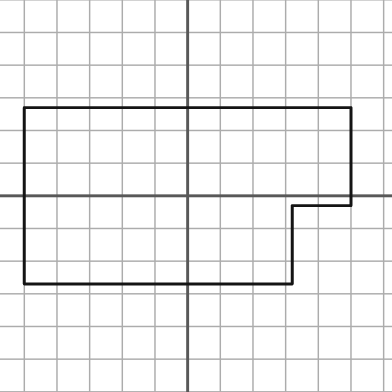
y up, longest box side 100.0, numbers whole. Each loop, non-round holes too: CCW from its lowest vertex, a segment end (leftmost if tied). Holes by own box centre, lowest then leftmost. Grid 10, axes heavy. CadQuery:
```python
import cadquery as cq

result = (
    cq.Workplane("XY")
    .moveTo(-50.0, -27.0)
    .lineTo(32.0, -27.0)
    .lineTo(32.0, -3.0)
    .lineTo(50.0, -3.0)
    .lineTo(50.0, 27.0)
    .lineTo(-50.0, 27.0)
    .close()
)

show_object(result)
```